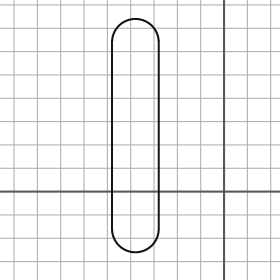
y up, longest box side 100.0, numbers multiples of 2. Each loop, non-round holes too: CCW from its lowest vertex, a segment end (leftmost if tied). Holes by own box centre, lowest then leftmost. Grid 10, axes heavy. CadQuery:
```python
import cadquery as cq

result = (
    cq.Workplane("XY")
    .moveTo(-48.0, -16.0)
    .threePointArc((-38.0, -26.0), (-28.0, -16.0))
    .lineTo(-28.0, 64.0)
    .threePointArc((-38.0, 74.0), (-48.0, 64.0))
    .close()
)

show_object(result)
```